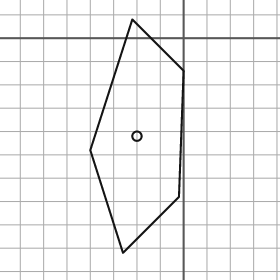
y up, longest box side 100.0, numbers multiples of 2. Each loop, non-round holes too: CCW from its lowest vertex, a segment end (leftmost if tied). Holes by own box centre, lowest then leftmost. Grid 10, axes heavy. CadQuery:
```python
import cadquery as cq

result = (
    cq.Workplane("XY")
    .moveTo(-26.0, -92.0)
    .lineTo(-2.0, -68.0)
    .lineTo(0.0, -14.0)
    .lineTo(-22.0, 8.0)
    .lineTo(-40.0, -48.0)
    .close()
    .moveTo(-20.0, -42.0)
    .circle(2.0)
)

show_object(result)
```